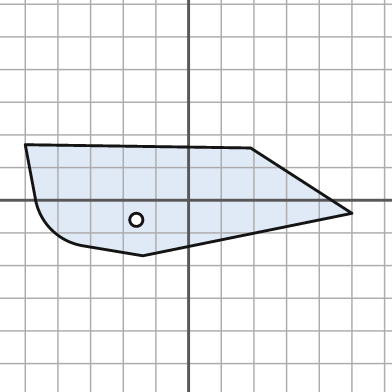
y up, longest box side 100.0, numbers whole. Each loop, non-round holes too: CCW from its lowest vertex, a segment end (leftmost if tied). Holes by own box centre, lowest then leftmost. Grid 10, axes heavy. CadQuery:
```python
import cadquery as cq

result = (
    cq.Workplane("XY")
    .moveTo(-14.0, -17.0)
    .lineTo(50.0, -4.0)
    .lineTo(19.0, 16.0)
    .lineTo(-50.0, 17.0)
    .lineTo(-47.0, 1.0)
    .threePointArc((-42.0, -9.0), (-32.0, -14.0))
    .close()
    .moveTo(-16.0, -6.0)
    .circle(2.0)
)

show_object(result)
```